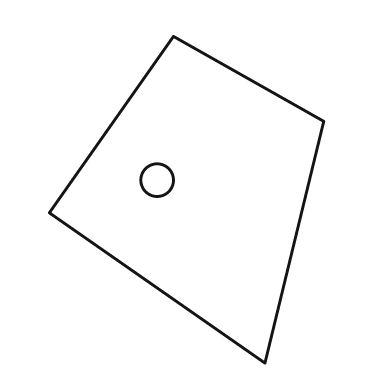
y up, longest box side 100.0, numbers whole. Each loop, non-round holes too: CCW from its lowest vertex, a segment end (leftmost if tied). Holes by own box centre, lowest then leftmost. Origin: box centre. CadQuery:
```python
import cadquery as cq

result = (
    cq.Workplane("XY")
    .moveTo(24.0, -50.0)
    .lineTo(42.0, 24.0)
    .lineTo(-4.0, 50.0)
    .lineTo(-42.0, -4.0)
    .close()
    .moveTo(-9.0, 6.0)
    .circle(5.0)
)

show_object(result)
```